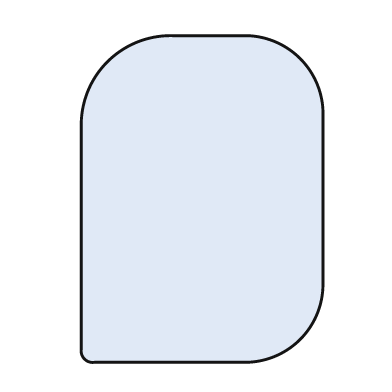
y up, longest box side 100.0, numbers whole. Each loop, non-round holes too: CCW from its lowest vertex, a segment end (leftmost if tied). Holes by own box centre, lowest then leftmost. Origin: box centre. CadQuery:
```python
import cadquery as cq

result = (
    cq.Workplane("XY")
    .moveTo(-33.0, -50.0)
    .lineTo(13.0, -50.0)
    .threePointArc((30.0, -43.0), (37.0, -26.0))
    .lineTo(37.0, 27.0)
    .threePointArc((30.0, 43.0), (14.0, 50.0))
    .lineTo(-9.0, 50.0)
    .threePointArc((-29.0, 42.0), (-37.0, 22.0))
    .lineTo(-37.0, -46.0)
    .threePointArc((-36.0, -49.0), (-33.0, -50.0))
    .close()
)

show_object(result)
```